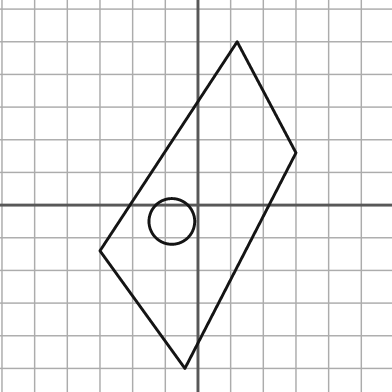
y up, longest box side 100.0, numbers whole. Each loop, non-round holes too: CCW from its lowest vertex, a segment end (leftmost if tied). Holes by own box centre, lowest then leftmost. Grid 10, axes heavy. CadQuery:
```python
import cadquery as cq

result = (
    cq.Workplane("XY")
    .moveTo(-4.0, -50.0)
    .lineTo(30.0, 16.0)
    .lineTo(12.0, 50.0)
    .lineTo(-30.0, -14.0)
    .close()
    .moveTo(-8.0, -5.0)
    .circle(7.0)
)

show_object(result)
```